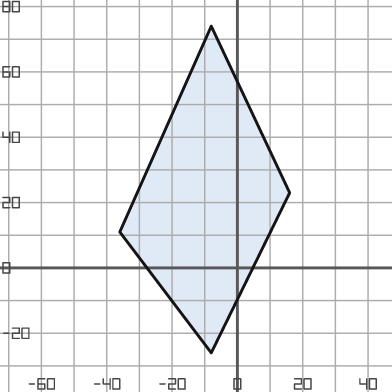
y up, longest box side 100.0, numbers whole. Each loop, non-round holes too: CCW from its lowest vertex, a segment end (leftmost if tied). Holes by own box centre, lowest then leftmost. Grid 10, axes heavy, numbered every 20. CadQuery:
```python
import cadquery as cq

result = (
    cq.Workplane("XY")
    .moveTo(-8.0, -26.0)
    .lineTo(16.0, 23.0)
    .lineTo(-8.0, 74.0)
    .lineTo(-36.0, 11.0)
    .close()
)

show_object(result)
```